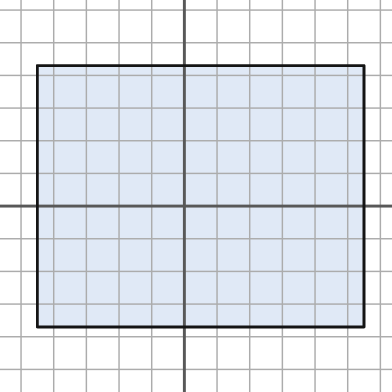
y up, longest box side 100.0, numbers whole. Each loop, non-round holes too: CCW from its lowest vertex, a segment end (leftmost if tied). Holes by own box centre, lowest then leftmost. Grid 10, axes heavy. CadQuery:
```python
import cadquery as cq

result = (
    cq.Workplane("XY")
    .moveTo(-45.0, -37.0)
    .lineTo(55.0, -37.0)
    .lineTo(55.0, 43.0)
    .lineTo(-45.0, 43.0)
    .close()
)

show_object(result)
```